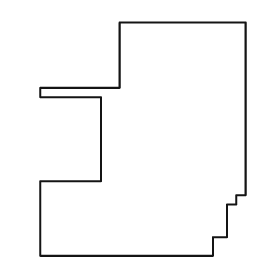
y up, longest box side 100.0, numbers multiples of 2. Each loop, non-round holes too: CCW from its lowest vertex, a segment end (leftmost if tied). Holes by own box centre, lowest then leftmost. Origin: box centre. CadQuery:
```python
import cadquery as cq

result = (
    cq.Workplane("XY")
    .moveTo(-44.0, -50.0)
    .lineTo(30.0, -50.0)
    .lineTo(30.0, -42.0)
    .lineTo(36.0, -42.0)
    .lineTo(36.0, -28.0)
    .lineTo(40.0, -28.0)
    .lineTo(40.0, -24.0)
    .lineTo(44.0, -24.0)
    .lineTo(44.0, 50.0)
    .lineTo(-10.0, 50.0)
    .lineTo(-10.0, 22.0)
    .lineTo(-44.0, 22.0)
    .lineTo(-44.0, 18.0)
    .lineTo(-18.0, 18.0)
    .lineTo(-18.0, -18.0)
    .lineTo(-44.0, -18.0)
    .close()
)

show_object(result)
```